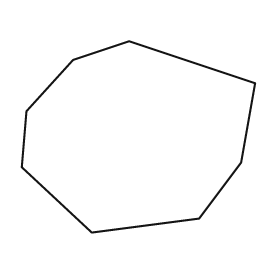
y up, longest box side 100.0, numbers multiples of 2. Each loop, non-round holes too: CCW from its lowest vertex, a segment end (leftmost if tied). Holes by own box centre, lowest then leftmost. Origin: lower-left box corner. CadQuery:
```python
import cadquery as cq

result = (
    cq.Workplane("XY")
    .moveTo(30.0, 0.0)
    .lineTo(76.0, 6.0)
    .lineTo(94.0, 30.0)
    .lineTo(100.0, 64.0)
    .lineTo(46.0, 82.0)
    .lineTo(22.0, 74.0)
    .lineTo(2.0, 52.0)
    .lineTo(0.0, 28.0)
    .close()
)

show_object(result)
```